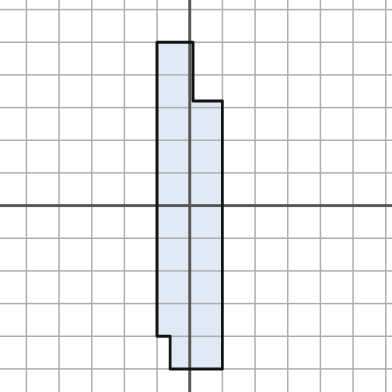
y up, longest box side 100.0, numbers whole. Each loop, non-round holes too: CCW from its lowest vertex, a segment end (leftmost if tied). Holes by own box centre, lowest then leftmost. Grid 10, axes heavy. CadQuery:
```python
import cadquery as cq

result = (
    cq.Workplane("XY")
    .moveTo(-6.0, -50.0)
    .lineTo(10.0, -50.0)
    .lineTo(10.0, 32.0)
    .lineTo(1.0, 32.0)
    .lineTo(1.0, 50.0)
    .lineTo(-10.0, 50.0)
    .lineTo(-10.0, -40.0)
    .lineTo(-6.0, -40.0)
    .close()
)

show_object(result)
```